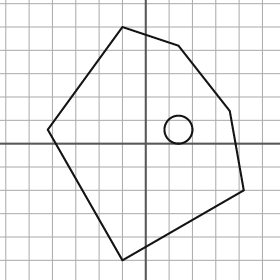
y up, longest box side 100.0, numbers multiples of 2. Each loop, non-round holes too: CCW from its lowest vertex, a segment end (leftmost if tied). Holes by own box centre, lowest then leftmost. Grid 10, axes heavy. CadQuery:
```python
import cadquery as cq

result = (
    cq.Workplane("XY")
    .moveTo(-10.0, -50.0)
    .lineTo(42.0, -20.0)
    .lineTo(36.0, 14.0)
    .lineTo(14.0, 42.0)
    .lineTo(-10.0, 50.0)
    .lineTo(-42.0, 6.0)
    .close()
    .moveTo(14.0, 6.0)
    .circle(6.0)
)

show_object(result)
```